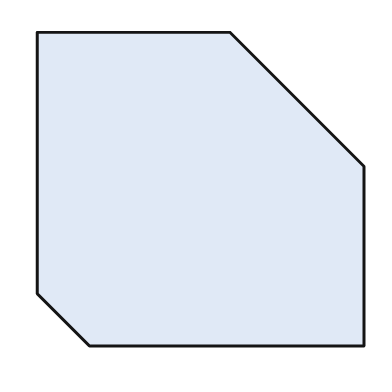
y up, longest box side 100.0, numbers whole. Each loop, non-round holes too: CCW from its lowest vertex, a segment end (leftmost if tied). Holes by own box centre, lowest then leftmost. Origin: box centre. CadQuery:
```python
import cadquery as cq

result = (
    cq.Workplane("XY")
    .moveTo(-34.0, -48.0)
    .lineTo(50.0, -48.0)
    .lineTo(50.0, 7.0)
    .lineTo(9.0, 48.0)
    .lineTo(-50.0, 48.0)
    .lineTo(-50.0, -32.0)
    .close()
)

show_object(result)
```